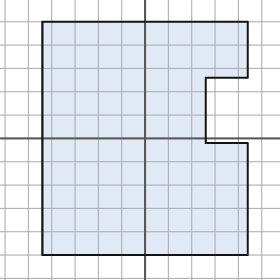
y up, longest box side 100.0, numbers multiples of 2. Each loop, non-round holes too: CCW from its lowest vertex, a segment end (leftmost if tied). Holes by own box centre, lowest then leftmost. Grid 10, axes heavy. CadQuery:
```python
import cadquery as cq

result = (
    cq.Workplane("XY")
    .moveTo(-44.0, -50.0)
    .lineTo(44.0, -50.0)
    .lineTo(44.0, -2.0)
    .lineTo(26.0, -2.0)
    .lineTo(26.0, 26.0)
    .lineTo(44.0, 26.0)
    .lineTo(44.0, 50.0)
    .lineTo(-44.0, 50.0)
    .close()
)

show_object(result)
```